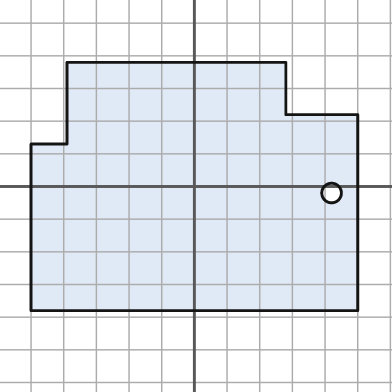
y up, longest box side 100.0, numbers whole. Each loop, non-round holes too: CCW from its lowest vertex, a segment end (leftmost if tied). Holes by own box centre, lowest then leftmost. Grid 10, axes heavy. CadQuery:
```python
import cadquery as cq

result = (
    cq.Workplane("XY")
    .moveTo(-50.0, -38.0)
    .lineTo(50.0, -38.0)
    .lineTo(50.0, 22.0)
    .lineTo(28.0, 22.0)
    .lineTo(28.0, 38.0)
    .lineTo(-39.0, 38.0)
    .lineTo(-39.0, 13.0)
    .lineTo(-50.0, 13.0)
    .close()
    .moveTo(42.0, -2.0)
    .circle(3.0)
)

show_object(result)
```